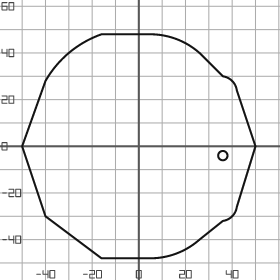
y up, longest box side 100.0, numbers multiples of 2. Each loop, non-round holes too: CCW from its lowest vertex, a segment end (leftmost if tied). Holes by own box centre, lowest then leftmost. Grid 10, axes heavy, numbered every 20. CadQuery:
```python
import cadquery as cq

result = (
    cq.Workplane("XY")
    .moveTo(-16.0, -48.0)
    .lineTo(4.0, -48.0)
    .threePointArc((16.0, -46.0), (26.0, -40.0))
    .lineTo(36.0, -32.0)
    .threePointArc((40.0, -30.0), (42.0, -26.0))
    .lineTo(50.0, 0.0)
    .lineTo(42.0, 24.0)
    .threePointArc((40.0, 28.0), (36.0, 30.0))
    .lineTo(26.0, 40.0)
    .threePointArc((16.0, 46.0), (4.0, 48.0))
    .lineTo(-16.0, 48.0)
    .threePointArc((-30.0, 40.0), (-40.0, 28.0))
    .lineTo(-50.0, 0.0)
    .lineTo(-40.0, -30.0)
    .close()
    .moveTo(36.0, -4.0)
    .circle(2.0)
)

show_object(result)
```